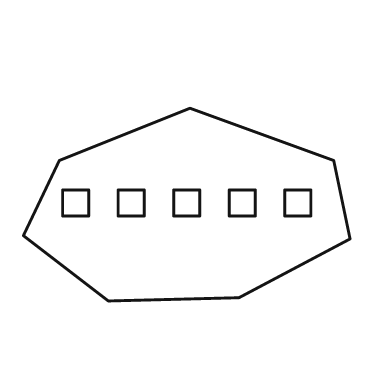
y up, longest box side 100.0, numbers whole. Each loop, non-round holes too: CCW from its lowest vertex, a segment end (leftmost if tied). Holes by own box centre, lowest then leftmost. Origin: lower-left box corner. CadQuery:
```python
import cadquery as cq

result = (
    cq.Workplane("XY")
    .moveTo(26.0, 0.0)
    .lineTo(66.0, 1.0)
    .lineTo(100.0, 19.0)
    .lineTo(95.0, 43.0)
    .lineTo(51.0, 59.0)
    .lineTo(11.0, 43.0)
    .lineTo(0.0, 20.0)
    .close()
    .moveTo(12.0, 26.0)
    .lineTo(20.0, 26.0)
    .lineTo(20.0, 34.0)
    .lineTo(12.0, 34.0)
    .close()
    .moveTo(29.0, 26.0)
    .lineTo(37.0, 26.0)
    .lineTo(37.0, 34.0)
    .lineTo(29.0, 34.0)
    .close()
    .moveTo(46.0, 26.0)
    .lineTo(54.0, 26.0)
    .lineTo(54.0, 34.0)
    .lineTo(46.0, 34.0)
    .close()
    .moveTo(63.0, 26.0)
    .lineTo(71.0, 26.0)
    .lineTo(71.0, 34.0)
    .lineTo(63.0, 34.0)
    .close()
    .moveTo(80.0, 26.0)
    .lineTo(88.0, 26.0)
    .lineTo(88.0, 34.0)
    .lineTo(80.0, 34.0)
    .close()
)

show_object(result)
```